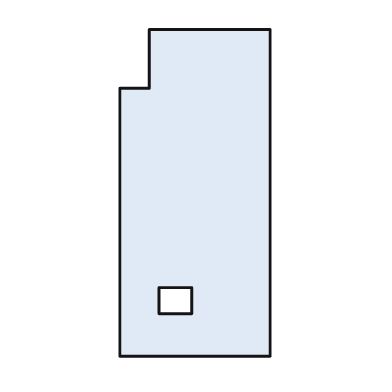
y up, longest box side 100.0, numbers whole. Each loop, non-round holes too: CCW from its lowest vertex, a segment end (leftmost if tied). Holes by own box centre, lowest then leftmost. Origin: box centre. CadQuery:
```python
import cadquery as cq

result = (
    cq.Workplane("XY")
    .moveTo(-23.0, -50.0)
    .lineTo(23.0, -50.0)
    .lineTo(23.0, 50.0)
    .lineTo(-14.0, 50.0)
    .lineTo(-14.0, 32.0)
    .lineTo(-23.0, 32.0)
    .close()
    .moveTo(-11.0, -37.0)
    .lineTo(-1.0, -37.0)
    .lineTo(-1.0, -29.0)
    .lineTo(-11.0, -29.0)
    .close()
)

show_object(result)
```